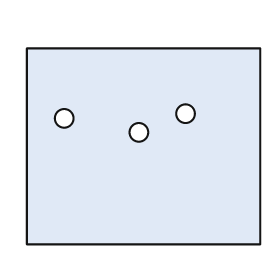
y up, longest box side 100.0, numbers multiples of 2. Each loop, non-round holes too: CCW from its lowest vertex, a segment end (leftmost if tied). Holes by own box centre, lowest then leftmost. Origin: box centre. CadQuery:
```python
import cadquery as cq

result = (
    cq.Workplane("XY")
    .moveTo(-50.0, -42.0)
    .lineTo(50.0, -42.0)
    .lineTo(50.0, 42.0)
    .lineTo(-50.0, 42.0)
    .close()
    .moveTo(-2.0, 6.0)
    .circle(4.0)
    .moveTo(-34.0, 12.0)
    .circle(4.0)
    .moveTo(18.0, 14.0)
    .circle(4.0)
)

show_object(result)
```